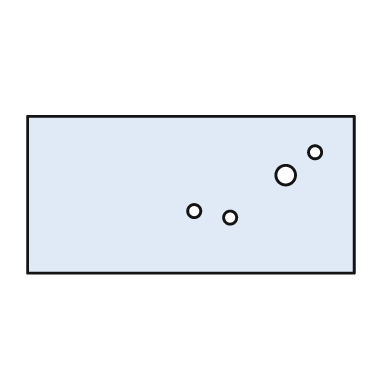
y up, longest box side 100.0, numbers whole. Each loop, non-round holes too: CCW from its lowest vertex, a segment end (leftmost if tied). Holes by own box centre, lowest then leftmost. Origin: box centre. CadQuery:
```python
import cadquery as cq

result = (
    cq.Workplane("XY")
    .moveTo(-50.0, -24.0)
    .lineTo(50.0, -24.0)
    .lineTo(50.0, 24.0)
    .lineTo(-50.0, 24.0)
    .close()
    .moveTo(12.0, -7.0)
    .circle(2.0)
    .moveTo(1.0, -5.0)
    .circle(2.0)
    .moveTo(29.0, 6.0)
    .circle(3.0)
    .moveTo(38.0, 13.0)
    .circle(2.0)
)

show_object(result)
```